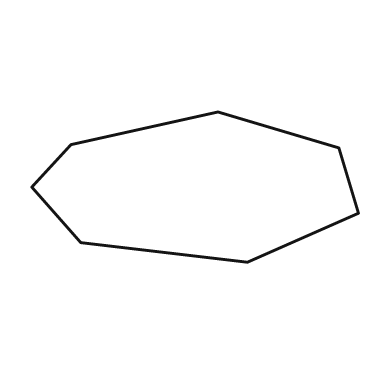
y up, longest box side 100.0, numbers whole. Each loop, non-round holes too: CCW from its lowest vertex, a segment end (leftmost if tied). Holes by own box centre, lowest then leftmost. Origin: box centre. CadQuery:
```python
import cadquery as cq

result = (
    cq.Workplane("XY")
    .moveTo(16.0, -23.0)
    .lineTo(50.0, -8.0)
    .lineTo(44.0, 12.0)
    .lineTo(7.0, 23.0)
    .lineTo(-38.0, 13.0)
    .lineTo(-50.0, 0.0)
    .lineTo(-35.0, -17.0)
    .close()
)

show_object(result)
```